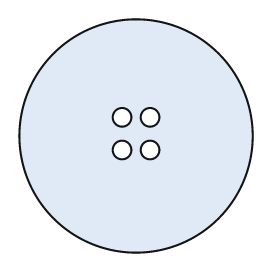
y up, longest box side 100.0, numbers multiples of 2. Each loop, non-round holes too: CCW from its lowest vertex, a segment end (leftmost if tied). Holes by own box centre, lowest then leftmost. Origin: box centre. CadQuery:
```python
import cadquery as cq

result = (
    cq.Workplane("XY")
    .moveTo(0.0, 0.0)
    .circle(50.0)
    .moveTo(-6.0, -6.0)
    .circle(4.0)
    .moveTo(6.0, -6.0)
    .circle(4.0)
    .moveTo(-6.0, 8.0)
    .circle(4.0)
    .moveTo(6.0, 8.0)
    .circle(4.0)
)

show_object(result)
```